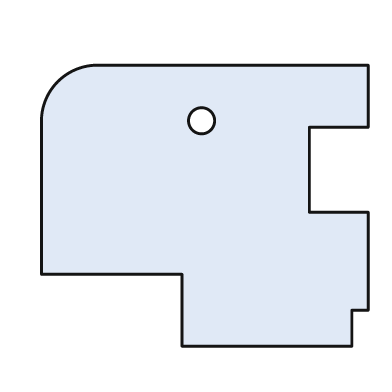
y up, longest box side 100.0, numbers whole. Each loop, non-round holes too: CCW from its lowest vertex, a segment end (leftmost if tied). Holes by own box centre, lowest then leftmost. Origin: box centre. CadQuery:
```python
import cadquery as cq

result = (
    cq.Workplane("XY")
    .moveTo(-7.0, -43.0)
    .lineTo(45.0, -43.0)
    .lineTo(45.0, -32.0)
    .lineTo(50.0, -32.0)
    .lineTo(50.0, -2.0)
    .lineTo(32.0, -2.0)
    .lineTo(32.0, 24.0)
    .lineTo(50.0, 24.0)
    .lineTo(50.0, 43.0)
    .lineTo(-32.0, 43.0)
    .threePointArc((-45.0, 38.0), (-50.0, 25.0))
    .lineTo(-50.0, -21.0)
    .lineTo(-7.0, -21.0)
    .close()
    .moveTo(-1.0, 26.0)
    .circle(4.0)
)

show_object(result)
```